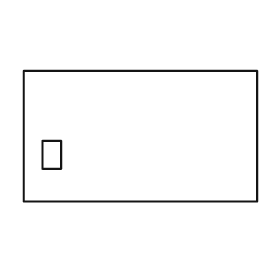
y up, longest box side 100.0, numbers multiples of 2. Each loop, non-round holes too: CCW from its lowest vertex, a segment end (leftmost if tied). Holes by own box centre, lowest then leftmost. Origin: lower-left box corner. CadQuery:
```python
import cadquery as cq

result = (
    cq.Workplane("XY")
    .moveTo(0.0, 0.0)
    .lineTo(100.0, 0.0)
    .lineTo(100.0, 56.0)
    .lineTo(0.0, 56.0)
    .close()
    .moveTo(8.0, 14.0)
    .lineTo(16.0, 14.0)
    .lineTo(16.0, 26.0)
    .lineTo(8.0, 26.0)
    .close()
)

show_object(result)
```